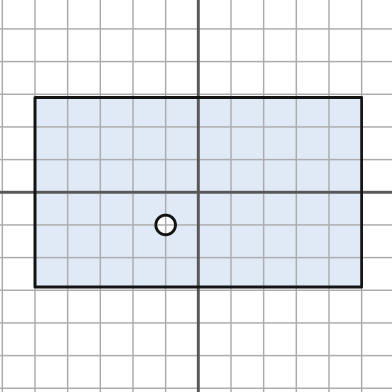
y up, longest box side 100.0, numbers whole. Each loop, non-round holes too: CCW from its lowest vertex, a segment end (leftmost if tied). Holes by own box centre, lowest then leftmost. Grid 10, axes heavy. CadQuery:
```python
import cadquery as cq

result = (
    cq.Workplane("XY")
    .moveTo(-50.0, -29.0)
    .lineTo(50.0, -29.0)
    .lineTo(50.0, 29.0)
    .lineTo(-50.0, 29.0)
    .close()
    .moveTo(-10.0, -10.0)
    .circle(3.0)
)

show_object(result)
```